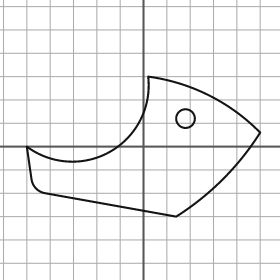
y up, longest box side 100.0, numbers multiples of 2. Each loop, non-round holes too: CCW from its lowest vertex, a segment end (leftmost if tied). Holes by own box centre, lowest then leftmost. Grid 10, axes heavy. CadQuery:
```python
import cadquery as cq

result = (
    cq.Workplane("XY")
    .moveTo(14.0, -30.0)
    .threePointArc((34.0, -14.0), (50.0, 6.0))
    .threePointArc((28.0, 22.0), (2.0, 30.0))
    .threePointArc((-14.0, -2.0), (-50.0, 0.0))
    .lineTo(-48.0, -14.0)
    .threePointArc((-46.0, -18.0), (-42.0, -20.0))
    .close()
    .moveTo(18.0, 12.0)
    .circle(4.0)
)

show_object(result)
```